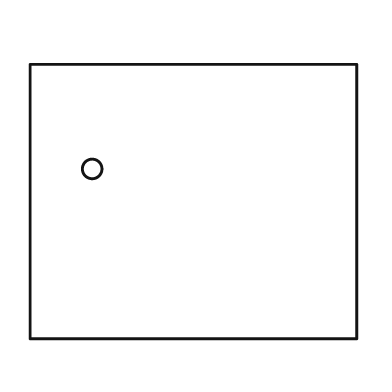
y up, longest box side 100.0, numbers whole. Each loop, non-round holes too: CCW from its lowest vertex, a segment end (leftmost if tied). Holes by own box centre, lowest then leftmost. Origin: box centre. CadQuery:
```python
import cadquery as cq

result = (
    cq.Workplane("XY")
    .moveTo(-50.0, -42.0)
    .lineTo(50.0, -42.0)
    .lineTo(50.0, 42.0)
    .lineTo(-50.0, 42.0)
    .close()
    .moveTo(-31.0, 10.0)
    .circle(3.0)
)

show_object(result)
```